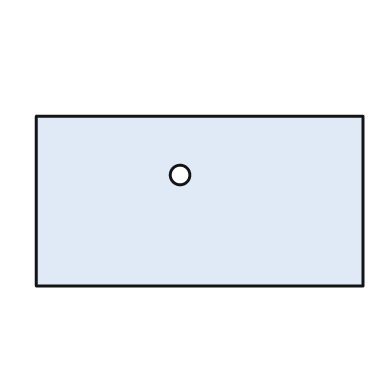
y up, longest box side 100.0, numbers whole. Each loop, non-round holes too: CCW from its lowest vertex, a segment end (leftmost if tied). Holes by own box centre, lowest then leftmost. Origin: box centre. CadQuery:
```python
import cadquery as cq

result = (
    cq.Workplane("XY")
    .moveTo(-50.0, -26.0)
    .lineTo(50.0, -26.0)
    .lineTo(50.0, 26.0)
    .lineTo(-50.0, 26.0)
    .close()
    .moveTo(-6.0, 8.0)
    .circle(3.0)
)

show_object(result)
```